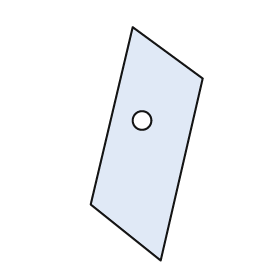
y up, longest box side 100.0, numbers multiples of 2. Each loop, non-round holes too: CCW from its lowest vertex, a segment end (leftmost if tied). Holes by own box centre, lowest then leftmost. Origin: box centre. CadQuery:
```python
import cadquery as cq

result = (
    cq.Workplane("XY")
    .moveTo(6.0, -50.0)
    .lineTo(24.0, 28.0)
    .lineTo(-6.0, 50.0)
    .lineTo(-24.0, -26.0)
    .close()
    .moveTo(-2.0, 10.0)
    .circle(4.0)
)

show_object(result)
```